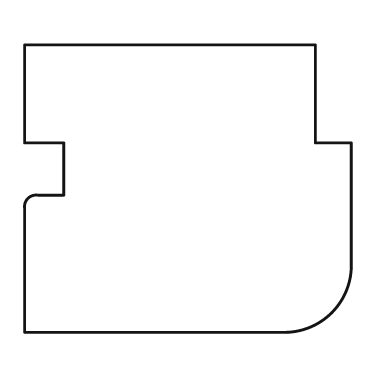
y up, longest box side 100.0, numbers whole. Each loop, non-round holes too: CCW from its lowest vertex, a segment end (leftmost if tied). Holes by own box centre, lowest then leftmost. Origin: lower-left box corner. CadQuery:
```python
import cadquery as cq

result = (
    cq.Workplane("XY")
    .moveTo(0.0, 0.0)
    .lineTo(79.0, 0.0)
    .threePointArc((94.0, 6.0), (100.0, 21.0))
    .lineTo(100.0, 58.0)
    .lineTo(89.0, 58.0)
    .lineTo(89.0, 88.0)
    .lineTo(0.0, 88.0)
    .lineTo(0.0, 58.0)
    .lineTo(12.0, 58.0)
    .lineTo(12.0, 42.0)
    .lineTo(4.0, 42.0)
    .threePointArc((1.0, 41.0), (0.0, 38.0))
    .close()
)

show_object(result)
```